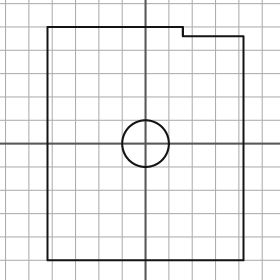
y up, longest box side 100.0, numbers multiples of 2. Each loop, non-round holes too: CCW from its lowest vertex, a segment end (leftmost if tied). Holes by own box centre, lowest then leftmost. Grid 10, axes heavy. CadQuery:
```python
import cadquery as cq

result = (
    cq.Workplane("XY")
    .moveTo(-42.0, -50.0)
    .lineTo(42.0, -50.0)
    .lineTo(42.0, 46.0)
    .lineTo(16.0, 46.0)
    .lineTo(16.0, 50.0)
    .lineTo(-42.0, 50.0)
    .close()
    .moveTo(0.0, 0.0)
    .circle(10.0)
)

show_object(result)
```